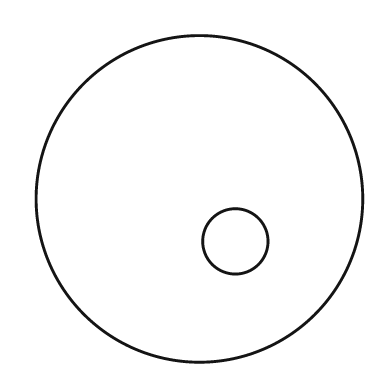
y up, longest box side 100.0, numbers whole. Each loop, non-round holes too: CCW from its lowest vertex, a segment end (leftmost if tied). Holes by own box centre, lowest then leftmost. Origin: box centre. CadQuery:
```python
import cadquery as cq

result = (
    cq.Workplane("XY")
    .moveTo(0.0, 0.0)
    .circle(50.0)
    .moveTo(11.0, -13.0)
    .circle(10.0)
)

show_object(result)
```